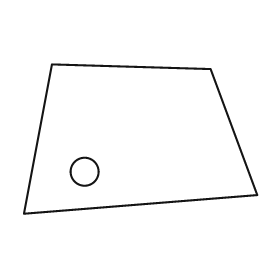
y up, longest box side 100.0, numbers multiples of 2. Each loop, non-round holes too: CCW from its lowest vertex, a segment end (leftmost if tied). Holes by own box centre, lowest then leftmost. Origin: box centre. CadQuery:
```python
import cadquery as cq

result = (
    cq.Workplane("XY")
    .moveTo(-50.0, -32.0)
    .lineTo(50.0, -24.0)
    .lineTo(30.0, 30.0)
    .lineTo(-38.0, 32.0)
    .close()
    .moveTo(-24.0, -14.0)
    .circle(6.0)
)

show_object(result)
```